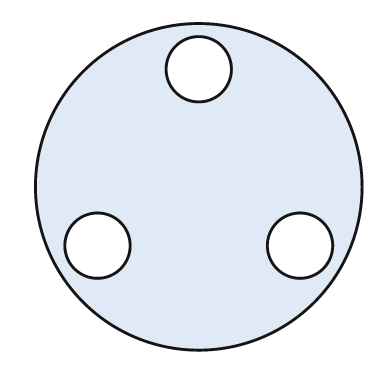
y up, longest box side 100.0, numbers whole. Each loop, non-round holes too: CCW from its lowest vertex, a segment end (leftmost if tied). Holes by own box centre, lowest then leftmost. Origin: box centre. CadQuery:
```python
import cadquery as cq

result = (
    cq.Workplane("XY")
    .moveTo(0.0, 0.0)
    .circle(50.0)
    .moveTo(-31.0, -18.0)
    .circle(10.0)
    .moveTo(31.0, -18.0)
    .circle(10.0)
    .moveTo(0.0, 36.0)
    .circle(10.0)
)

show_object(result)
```